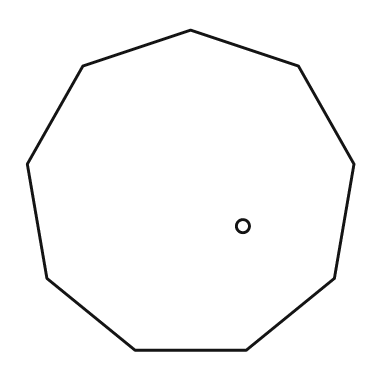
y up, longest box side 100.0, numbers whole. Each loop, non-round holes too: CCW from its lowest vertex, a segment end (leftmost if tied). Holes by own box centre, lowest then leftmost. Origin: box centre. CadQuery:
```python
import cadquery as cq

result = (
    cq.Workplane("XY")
    .moveTo(-17.0, -49.0)
    .lineTo(17.0, -49.0)
    .lineTo(44.0, -27.0)
    .lineTo(50.0, 8.0)
    .lineTo(33.0, 38.0)
    .lineTo(0.0, 49.0)
    .lineTo(-33.0, 38.0)
    .lineTo(-50.0, 8.0)
    .lineTo(-44.0, -27.0)
    .close()
    .moveTo(16.0, -11.0)
    .circle(2.0)
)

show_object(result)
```